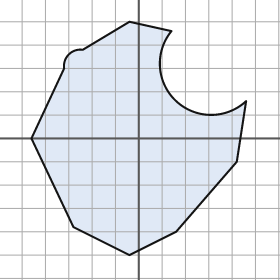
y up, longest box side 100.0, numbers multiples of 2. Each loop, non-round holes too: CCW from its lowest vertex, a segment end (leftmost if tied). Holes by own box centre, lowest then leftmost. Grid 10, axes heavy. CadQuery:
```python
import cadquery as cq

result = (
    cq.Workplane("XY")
    .moveTo(-4.0, -50.0)
    .lineTo(16.0, -40.0)
    .lineTo(42.0, -10.0)
    .lineTo(46.0, 16.0)
    .threePointArc((16.0, 16.0), (14.0, 46.0))
    .lineTo(-4.0, 50.0)
    .lineTo(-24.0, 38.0)
    .threePointArc((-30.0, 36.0), (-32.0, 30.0))
    .lineTo(-46.0, 0.0)
    .lineTo(-28.0, -38.0)
    .close()
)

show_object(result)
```